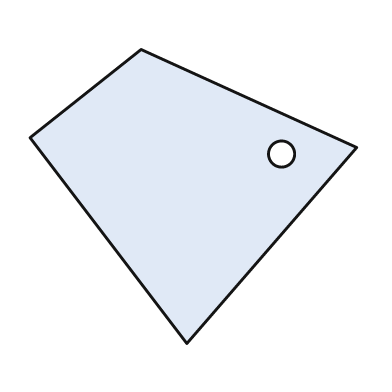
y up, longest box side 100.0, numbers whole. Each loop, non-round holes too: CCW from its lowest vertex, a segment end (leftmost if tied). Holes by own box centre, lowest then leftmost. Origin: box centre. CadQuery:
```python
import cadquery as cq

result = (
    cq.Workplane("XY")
    .moveTo(-2.0, -45.0)
    .lineTo(50.0, 15.0)
    .lineTo(-16.0, 45.0)
    .lineTo(-50.0, 18.0)
    .close()
    .moveTo(27.0, 13.0)
    .circle(4.0)
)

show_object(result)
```